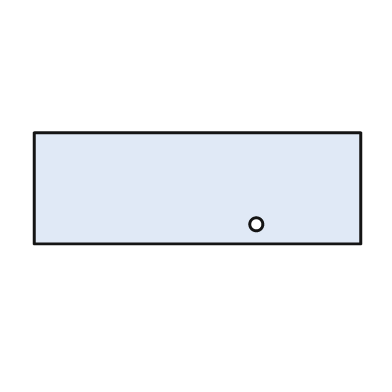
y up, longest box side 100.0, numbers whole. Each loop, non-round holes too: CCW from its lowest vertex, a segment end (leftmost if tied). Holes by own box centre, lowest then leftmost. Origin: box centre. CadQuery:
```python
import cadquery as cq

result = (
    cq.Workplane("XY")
    .moveTo(-50.0, -17.0)
    .lineTo(50.0, -17.0)
    .lineTo(50.0, 17.0)
    .lineTo(-50.0, 17.0)
    .close()
    .moveTo(18.0, -11.0)
    .circle(2.0)
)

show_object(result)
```